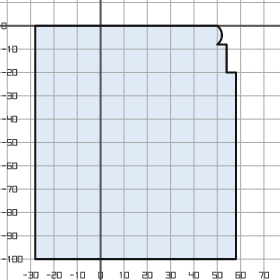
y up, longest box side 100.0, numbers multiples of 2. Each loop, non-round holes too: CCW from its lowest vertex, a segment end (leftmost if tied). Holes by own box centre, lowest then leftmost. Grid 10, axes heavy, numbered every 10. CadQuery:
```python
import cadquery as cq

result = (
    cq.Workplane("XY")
    .moveTo(-28.0, -100.0)
    .lineTo(58.0, -100.0)
    .lineTo(58.0, -20.0)
    .lineTo(54.0, -20.0)
    .lineTo(54.0, -8.0)
    .lineTo(50.0, -8.0)
    .threePointArc((52.0, -4.0), (50.0, 0.0))
    .lineTo(-28.0, 0.0)
    .close()
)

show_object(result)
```